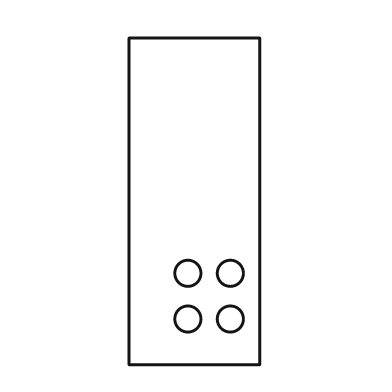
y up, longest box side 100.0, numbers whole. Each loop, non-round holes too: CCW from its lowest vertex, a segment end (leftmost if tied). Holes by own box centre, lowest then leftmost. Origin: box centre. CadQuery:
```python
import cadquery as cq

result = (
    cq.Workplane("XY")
    .moveTo(-20.0, -50.0)
    .lineTo(20.0, -50.0)
    .lineTo(20.0, 50.0)
    .lineTo(-20.0, 50.0)
    .close()
    .moveTo(-2.0, -36.0)
    .circle(4.0)
    .moveTo(11.0, -36.0)
    .circle(4.0)
    .moveTo(-2.0, -22.0)
    .circle(4.0)
    .moveTo(11.0, -22.0)
    .circle(4.0)
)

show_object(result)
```